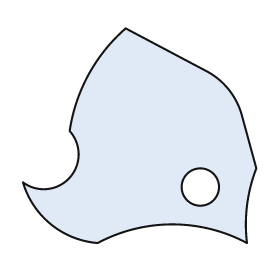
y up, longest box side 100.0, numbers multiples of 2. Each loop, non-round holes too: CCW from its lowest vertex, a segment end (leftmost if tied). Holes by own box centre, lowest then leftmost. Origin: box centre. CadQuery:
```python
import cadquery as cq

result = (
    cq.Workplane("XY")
    .moveTo(-18.0, -46.0)
    .threePointArc((14.0, -38.0), (46.0, -46.0))
    .threePointArc((46.0, -30.0), (50.0, -14.0))
    .lineTo(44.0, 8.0)
    .threePointArc((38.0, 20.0), (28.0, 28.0))
    .lineTo(-6.0, 46.0)
    .threePointArc((-22.0, 26.0), (-30.0, 2.0))
    .threePointArc((-30.0, -18.0), (-50.0, -20.0))
    .threePointArc((-38.0, -38.0), (-18.0, -46.0))
    .close()
    .moveTo(26.0, -22.0)
    .circle(8.0)
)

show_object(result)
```